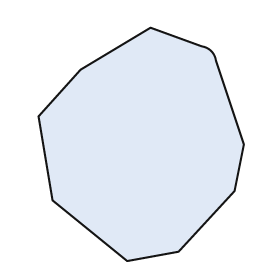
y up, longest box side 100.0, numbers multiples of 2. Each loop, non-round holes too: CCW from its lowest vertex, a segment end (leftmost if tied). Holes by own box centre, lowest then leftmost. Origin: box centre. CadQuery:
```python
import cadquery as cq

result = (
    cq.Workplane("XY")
    .moveTo(-6.0, -50.0)
    .lineTo(16.0, -46.0)
    .lineTo(40.0, -20.0)
    .lineTo(44.0, 0.0)
    .lineTo(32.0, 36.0)
    .threePointArc((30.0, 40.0), (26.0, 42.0))
    .lineTo(4.0, 50.0)
    .lineTo(-26.0, 32.0)
    .lineTo(-44.0, 12.0)
    .lineTo(-38.0, -24.0)
    .close()
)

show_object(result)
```